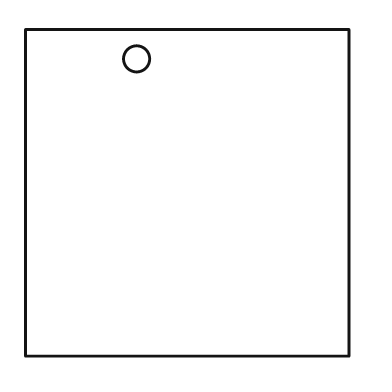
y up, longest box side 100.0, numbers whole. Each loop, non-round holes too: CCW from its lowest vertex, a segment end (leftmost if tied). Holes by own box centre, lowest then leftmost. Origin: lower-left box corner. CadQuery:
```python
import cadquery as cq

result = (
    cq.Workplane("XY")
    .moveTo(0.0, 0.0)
    .lineTo(99.0, 0.0)
    .lineTo(99.0, 100.0)
    .lineTo(0.0, 100.0)
    .close()
    .moveTo(34.0, 91.0)
    .circle(4.0)
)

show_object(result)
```